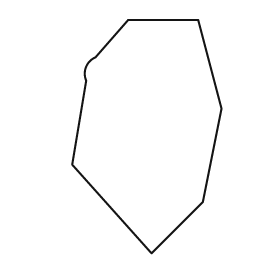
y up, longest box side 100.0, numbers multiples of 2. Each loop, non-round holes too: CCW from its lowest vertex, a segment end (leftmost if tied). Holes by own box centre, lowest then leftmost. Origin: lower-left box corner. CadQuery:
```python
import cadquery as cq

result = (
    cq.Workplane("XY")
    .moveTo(34.0, 0.0)
    .lineTo(56.0, 22.0)
    .lineTo(64.0, 62.0)
    .lineTo(54.0, 100.0)
    .lineTo(24.0, 100.0)
    .lineTo(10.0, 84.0)
    .threePointArc((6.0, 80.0), (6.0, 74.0))
    .lineTo(0.0, 38.0)
    .close()
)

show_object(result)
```